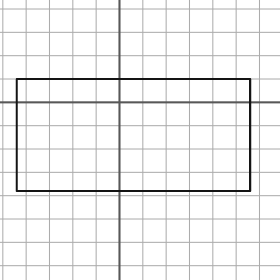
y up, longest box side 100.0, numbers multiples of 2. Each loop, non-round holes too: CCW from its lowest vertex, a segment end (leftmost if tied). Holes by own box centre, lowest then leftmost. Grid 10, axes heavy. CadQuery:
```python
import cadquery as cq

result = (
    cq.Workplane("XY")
    .moveTo(-44.0, -38.0)
    .lineTo(56.0, -38.0)
    .lineTo(56.0, 10.0)
    .lineTo(-44.0, 10.0)
    .close()
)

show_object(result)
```